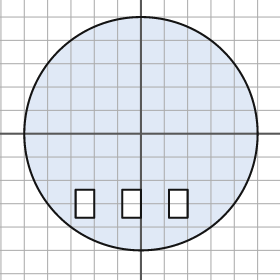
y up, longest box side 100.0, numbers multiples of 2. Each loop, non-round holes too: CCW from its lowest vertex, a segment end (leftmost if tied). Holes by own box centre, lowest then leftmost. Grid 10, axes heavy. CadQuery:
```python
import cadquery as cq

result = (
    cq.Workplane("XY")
    .moveTo(0.0, 0.0)
    .circle(50.0)
    .moveTo(-28.0, -36.0)
    .lineTo(-20.0, -36.0)
    .lineTo(-20.0, -24.0)
    .lineTo(-28.0, -24.0)
    .close()
    .moveTo(-8.0, -36.0)
    .lineTo(0.0, -36.0)
    .lineTo(0.0, -24.0)
    .lineTo(-8.0, -24.0)
    .close()
    .moveTo(12.0, -36.0)
    .lineTo(20.0, -36.0)
    .lineTo(20.0, -24.0)
    .lineTo(12.0, -24.0)
    .close()
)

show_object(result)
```